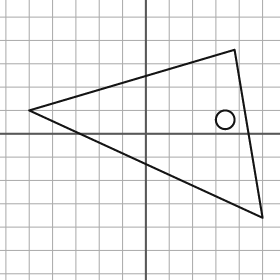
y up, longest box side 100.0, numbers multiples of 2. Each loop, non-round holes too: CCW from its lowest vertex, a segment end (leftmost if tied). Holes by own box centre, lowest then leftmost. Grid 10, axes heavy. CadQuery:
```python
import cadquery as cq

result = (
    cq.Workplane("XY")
    .moveTo(50.0, -36.0)
    .lineTo(38.0, 36.0)
    .lineTo(-50.0, 10.0)
    .close()
    .moveTo(34.0, 6.0)
    .circle(4.0)
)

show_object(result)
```